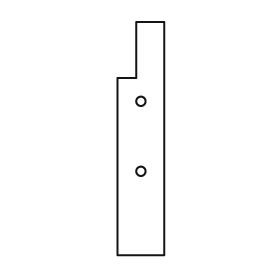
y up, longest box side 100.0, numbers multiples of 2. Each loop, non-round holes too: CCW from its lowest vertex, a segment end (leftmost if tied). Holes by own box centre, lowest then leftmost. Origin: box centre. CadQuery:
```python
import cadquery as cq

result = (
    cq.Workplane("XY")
    .moveTo(-10.0, -50.0)
    .lineTo(10.0, -50.0)
    .lineTo(10.0, 50.0)
    .lineTo(-2.0, 50.0)
    .lineTo(-2.0, 26.0)
    .lineTo(-10.0, 26.0)
    .close()
    .moveTo(0.0, -14.0)
    .circle(2.0)
    .moveTo(0.0, 16.0)
    .circle(2.0)
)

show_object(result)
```